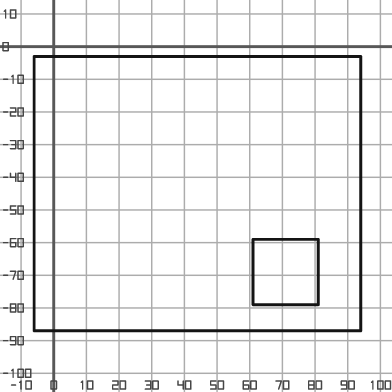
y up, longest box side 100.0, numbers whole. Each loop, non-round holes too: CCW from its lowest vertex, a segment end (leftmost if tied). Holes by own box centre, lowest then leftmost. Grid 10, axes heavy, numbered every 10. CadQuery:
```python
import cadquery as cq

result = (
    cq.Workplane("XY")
    .moveTo(-6.0, -87.0)
    .lineTo(94.0, -87.0)
    .lineTo(94.0, -3.0)
    .lineTo(-6.0, -3.0)
    .close()
    .moveTo(61.0, -79.0)
    .lineTo(81.0, -79.0)
    .lineTo(81.0, -59.0)
    .lineTo(61.0, -59.0)
    .close()
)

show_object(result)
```